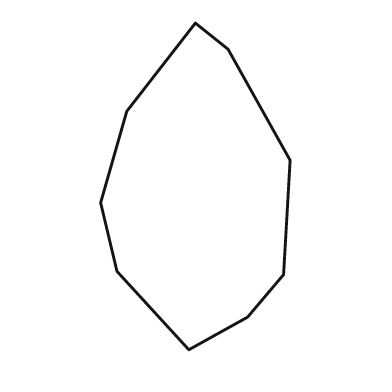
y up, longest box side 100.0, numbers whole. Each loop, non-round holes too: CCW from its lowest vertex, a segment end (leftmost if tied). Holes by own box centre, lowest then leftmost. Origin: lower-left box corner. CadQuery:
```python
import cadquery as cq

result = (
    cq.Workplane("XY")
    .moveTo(27.0, 0.0)
    .lineTo(45.0, 10.0)
    .lineTo(56.0, 23.0)
    .lineTo(58.0, 58.0)
    .lineTo(39.0, 92.0)
    .lineTo(29.0, 100.0)
    .lineTo(8.0, 73.0)
    .lineTo(0.0, 45.0)
    .lineTo(5.0, 24.0)
    .close()
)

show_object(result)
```